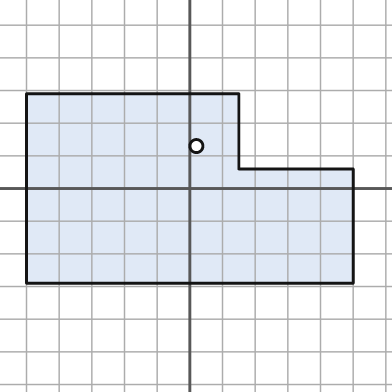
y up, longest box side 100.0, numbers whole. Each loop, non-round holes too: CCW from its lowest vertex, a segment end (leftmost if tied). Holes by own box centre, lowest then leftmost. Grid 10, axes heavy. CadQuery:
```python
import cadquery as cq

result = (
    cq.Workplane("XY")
    .moveTo(-50.0, -29.0)
    .lineTo(50.0, -29.0)
    .lineTo(50.0, 6.0)
    .lineTo(15.0, 6.0)
    .lineTo(15.0, 29.0)
    .lineTo(-50.0, 29.0)
    .close()
    .moveTo(2.0, 13.0)
    .circle(2.0)
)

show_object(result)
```